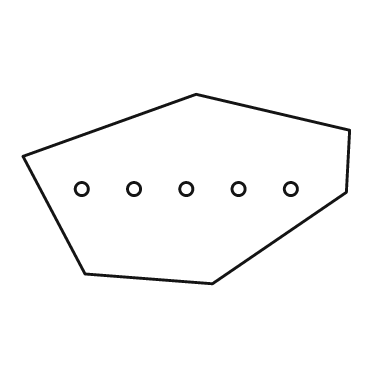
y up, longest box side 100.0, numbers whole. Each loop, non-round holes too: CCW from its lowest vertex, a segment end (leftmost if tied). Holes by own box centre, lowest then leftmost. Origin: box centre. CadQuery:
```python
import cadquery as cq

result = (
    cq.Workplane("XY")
    .moveTo(8.0, -29.0)
    .lineTo(49.0, -1.0)
    .lineTo(50.0, 18.0)
    .lineTo(3.0, 29.0)
    .lineTo(-50.0, 10.0)
    .lineTo(-31.0, -26.0)
    .close()
    .moveTo(-32.0, 0.0)
    .circle(2.0)
    .moveTo(-16.0, 0.0)
    .circle(2.0)
    .moveTo(0.0, 0.0)
    .circle(2.0)
    .moveTo(16.0, 0.0)
    .circle(2.0)
    .moveTo(32.0, 0.0)
    .circle(2.0)
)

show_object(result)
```